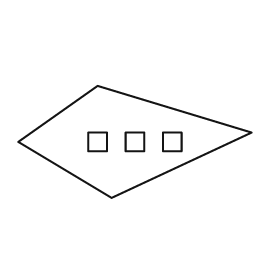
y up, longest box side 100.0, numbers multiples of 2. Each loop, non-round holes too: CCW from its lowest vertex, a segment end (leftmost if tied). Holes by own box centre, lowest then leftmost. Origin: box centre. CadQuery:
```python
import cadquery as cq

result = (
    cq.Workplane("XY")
    .moveTo(-10.0, -24.0)
    .lineTo(50.0, 4.0)
    .lineTo(-16.0, 24.0)
    .lineTo(-50.0, 0.0)
    .close()
    .moveTo(-20.0, -4.0)
    .lineTo(-12.0, -4.0)
    .lineTo(-12.0, 4.0)
    .lineTo(-20.0, 4.0)
    .close()
    .moveTo(-4.0, -4.0)
    .lineTo(4.0, -4.0)
    .lineTo(4.0, 4.0)
    .lineTo(-4.0, 4.0)
    .close()
    .moveTo(12.0, -4.0)
    .lineTo(20.0, -4.0)
    .lineTo(20.0, 4.0)
    .lineTo(12.0, 4.0)
    .close()
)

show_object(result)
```